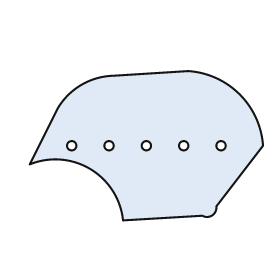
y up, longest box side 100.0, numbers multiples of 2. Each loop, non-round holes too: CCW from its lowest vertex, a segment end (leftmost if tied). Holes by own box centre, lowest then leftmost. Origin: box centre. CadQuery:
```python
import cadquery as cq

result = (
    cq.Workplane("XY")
    .moveTo(-10.0, -32.0)
    .lineTo(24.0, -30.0)
    .threePointArc((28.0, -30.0), (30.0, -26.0))
    .lineTo(50.0, 0.0)
    .threePointArc((40.0, 22.0), (18.0, 32.0))
    .lineTo(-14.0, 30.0)
    .threePointArc((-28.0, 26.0), (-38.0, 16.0))
    .lineTo(-50.0, -8.0)
    .threePointArc((-24.0, -10.0), (-10.0, -32.0))
    .close()
    .moveTo(-32.0, 0.0)
    .circle(2.0)
    .moveTo(-16.0, 0.0)
    .circle(2.0)
    .moveTo(0.0, 0.0)
    .circle(2.0)
    .moveTo(16.0, 0.0)
    .circle(2.0)
    .moveTo(32.0, 0.0)
    .circle(2.0)
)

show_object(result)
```